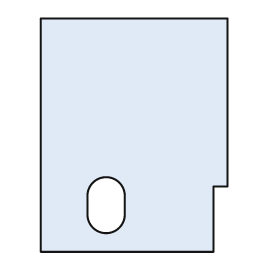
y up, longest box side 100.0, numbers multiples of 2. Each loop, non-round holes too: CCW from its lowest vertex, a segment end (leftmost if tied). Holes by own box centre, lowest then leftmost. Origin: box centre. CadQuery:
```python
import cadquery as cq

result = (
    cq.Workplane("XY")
    .moveTo(-40.0, -50.0)
    .lineTo(34.0, -50.0)
    .lineTo(34.0, -22.0)
    .lineTo(40.0, -22.0)
    .lineTo(40.0, 50.0)
    .lineTo(-40.0, 50.0)
    .close()
    .moveTo(-20.0, -34.0)
    .threePointArc((-12.0, -42.0), (-4.0, -34.0))
    .lineTo(-4.0, -26.0)
    .threePointArc((-12.0, -18.0), (-20.0, -26.0))
    .close()
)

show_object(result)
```